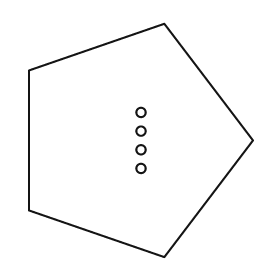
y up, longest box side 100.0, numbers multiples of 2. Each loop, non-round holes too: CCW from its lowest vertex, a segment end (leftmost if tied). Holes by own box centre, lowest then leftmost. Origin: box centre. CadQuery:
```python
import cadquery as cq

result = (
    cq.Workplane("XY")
    .moveTo(10.0, -50.0)
    .lineTo(48.0, 0.0)
    .lineTo(10.0, 50.0)
    .lineTo(-48.0, 30.0)
    .lineTo(-48.0, -30.0)
    .close()
    .moveTo(0.0, -12.0)
    .circle(2.0)
    .moveTo(0.0, -4.0)
    .circle(2.0)
    .moveTo(0.0, 4.0)
    .circle(2.0)
    .moveTo(0.0, 12.0)
    .circle(2.0)
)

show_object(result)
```